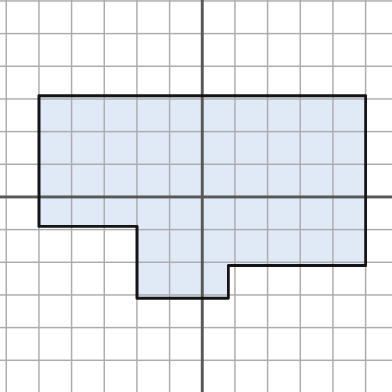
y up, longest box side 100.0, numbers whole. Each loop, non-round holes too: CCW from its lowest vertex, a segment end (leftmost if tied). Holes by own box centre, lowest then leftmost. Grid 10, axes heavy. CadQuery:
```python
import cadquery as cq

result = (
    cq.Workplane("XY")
    .moveTo(-20.0, -31.0)
    .lineTo(8.0, -31.0)
    .lineTo(8.0, -21.0)
    .lineTo(50.0, -21.0)
    .lineTo(50.0, 31.0)
    .lineTo(-50.0, 31.0)
    .lineTo(-50.0, -9.0)
    .lineTo(-20.0, -9.0)
    .close()
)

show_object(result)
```